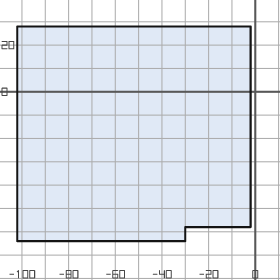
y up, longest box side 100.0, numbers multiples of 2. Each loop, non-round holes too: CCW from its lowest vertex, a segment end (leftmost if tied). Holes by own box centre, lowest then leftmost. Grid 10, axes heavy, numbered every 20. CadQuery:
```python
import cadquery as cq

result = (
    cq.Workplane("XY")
    .moveTo(-102.0, -64.0)
    .lineTo(-30.0, -64.0)
    .lineTo(-30.0, -58.0)
    .lineTo(-2.0, -58.0)
    .lineTo(-2.0, 28.0)
    .lineTo(-102.0, 28.0)
    .close()
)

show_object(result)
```